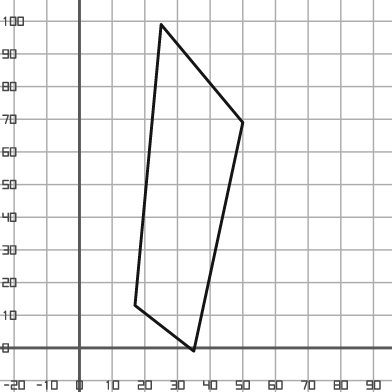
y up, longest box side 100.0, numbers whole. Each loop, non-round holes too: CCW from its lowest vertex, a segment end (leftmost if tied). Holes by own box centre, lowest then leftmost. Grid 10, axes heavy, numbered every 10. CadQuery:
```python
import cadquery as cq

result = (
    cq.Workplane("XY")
    .moveTo(35.0, -1.0)
    .lineTo(50.0, 69.0)
    .lineTo(25.0, 99.0)
    .lineTo(17.0, 13.0)
    .close()
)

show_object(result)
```